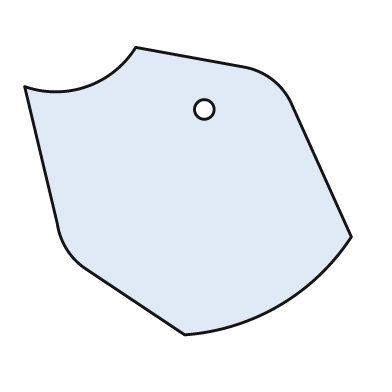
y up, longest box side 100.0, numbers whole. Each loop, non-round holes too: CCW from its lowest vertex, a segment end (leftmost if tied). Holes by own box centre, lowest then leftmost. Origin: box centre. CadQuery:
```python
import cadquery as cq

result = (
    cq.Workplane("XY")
    .moveTo(-1.0, -44.0)
    .threePointArc((28.0, -35.0), (50.0, -14.0))
    .lineTo(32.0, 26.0)
    .threePointArc((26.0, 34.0), (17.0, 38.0))
    .lineTo(-16.0, 44.0)
    .threePointArc((-31.0, 32.0), (-50.0, 32.0))
    .lineTo(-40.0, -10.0)
    .threePointArc((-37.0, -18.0), (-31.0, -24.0))
    .close()
    .moveTo(5.0, 25.0)
    .circle(3.0)
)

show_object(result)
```